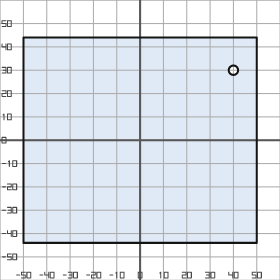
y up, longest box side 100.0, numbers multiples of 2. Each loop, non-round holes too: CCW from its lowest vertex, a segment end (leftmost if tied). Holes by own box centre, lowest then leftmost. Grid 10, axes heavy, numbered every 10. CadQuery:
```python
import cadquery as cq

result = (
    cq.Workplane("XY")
    .moveTo(-50.0, -44.0)
    .lineTo(50.0, -44.0)
    .lineTo(50.0, 44.0)
    .lineTo(-50.0, 44.0)
    .close()
    .moveTo(40.0, 30.0)
    .circle(2.0)
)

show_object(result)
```